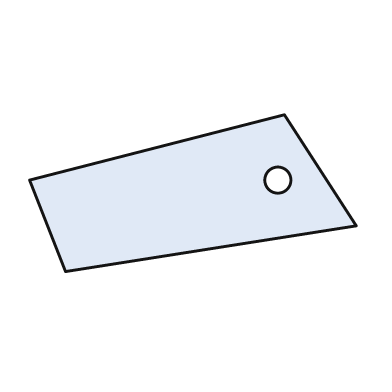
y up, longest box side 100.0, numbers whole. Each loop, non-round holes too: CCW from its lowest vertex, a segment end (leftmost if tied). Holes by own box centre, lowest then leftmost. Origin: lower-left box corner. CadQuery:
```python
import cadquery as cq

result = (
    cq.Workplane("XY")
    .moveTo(11.0, 0.0)
    .lineTo(100.0, 14.0)
    .lineTo(78.0, 48.0)
    .lineTo(0.0, 28.0)
    .close()
    .moveTo(76.0, 28.0)
    .circle(4.0)
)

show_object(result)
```